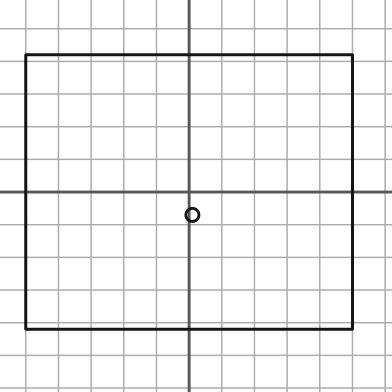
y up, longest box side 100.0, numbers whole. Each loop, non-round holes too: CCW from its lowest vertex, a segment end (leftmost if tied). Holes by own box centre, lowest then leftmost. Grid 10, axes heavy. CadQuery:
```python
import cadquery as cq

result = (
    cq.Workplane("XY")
    .moveTo(-50.0, -42.0)
    .lineTo(50.0, -42.0)
    .lineTo(50.0, 42.0)
    .lineTo(-50.0, 42.0)
    .close()
    .moveTo(1.0, -7.0)
    .circle(2.0)
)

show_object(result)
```